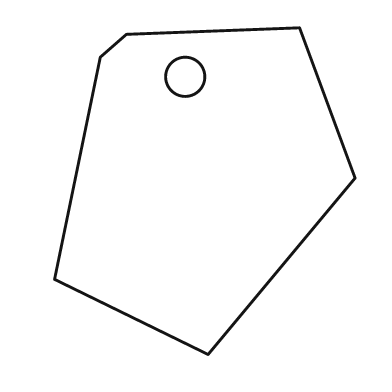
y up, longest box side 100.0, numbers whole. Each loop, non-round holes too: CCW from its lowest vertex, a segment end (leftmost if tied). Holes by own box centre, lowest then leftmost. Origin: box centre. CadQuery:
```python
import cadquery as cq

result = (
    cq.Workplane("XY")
    .moveTo(1.0, -50.0)
    .lineTo(46.0, 4.0)
    .lineTo(29.0, 50.0)
    .lineTo(-24.0, 48.0)
    .lineTo(-32.0, 41.0)
    .lineTo(-46.0, -27.0)
    .close()
    .moveTo(-6.0, 35.0)
    .circle(6.0)
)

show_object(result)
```